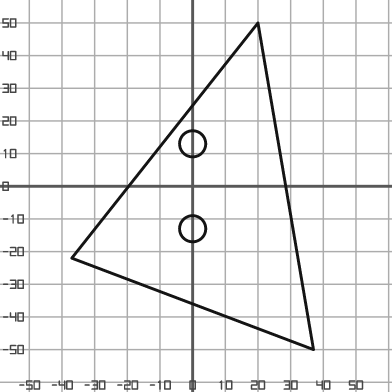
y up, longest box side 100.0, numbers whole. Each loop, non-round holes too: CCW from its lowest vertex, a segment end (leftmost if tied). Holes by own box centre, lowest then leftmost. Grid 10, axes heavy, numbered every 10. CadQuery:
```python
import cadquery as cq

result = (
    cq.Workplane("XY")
    .moveTo(37.0, -50.0)
    .lineTo(20.0, 50.0)
    .lineTo(-37.0, -22.0)
    .close()
    .moveTo(0.0, -13.0)
    .circle(4.0)
    .moveTo(0.0, 13.0)
    .circle(4.0)
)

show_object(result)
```